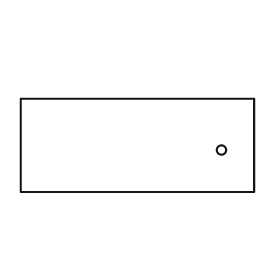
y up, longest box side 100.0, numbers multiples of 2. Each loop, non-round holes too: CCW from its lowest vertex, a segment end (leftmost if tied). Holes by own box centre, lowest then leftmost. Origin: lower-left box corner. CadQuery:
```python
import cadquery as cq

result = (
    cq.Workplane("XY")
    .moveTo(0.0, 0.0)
    .lineTo(100.0, 0.0)
    .lineTo(100.0, 40.0)
    .lineTo(0.0, 40.0)
    .close()
    .moveTo(86.0, 18.0)
    .circle(2.0)
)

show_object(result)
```